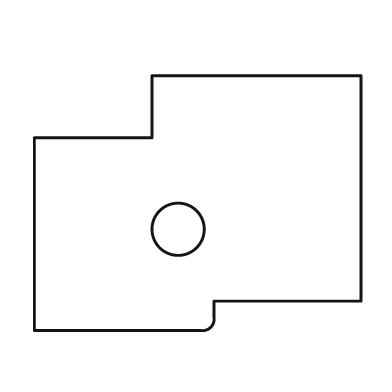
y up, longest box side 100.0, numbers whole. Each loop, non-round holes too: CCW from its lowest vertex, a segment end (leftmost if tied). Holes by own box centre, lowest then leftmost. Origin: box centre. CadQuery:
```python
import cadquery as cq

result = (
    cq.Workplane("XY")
    .moveTo(-50.0, -39.0)
    .lineTo(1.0, -39.0)
    .threePointArc((4.0, -38.0), (5.0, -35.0))
    .lineTo(5.0, -30.0)
    .lineTo(50.0, -30.0)
    .lineTo(50.0, 39.0)
    .lineTo(-14.0, 39.0)
    .lineTo(-14.0, 20.0)
    .lineTo(-50.0, 20.0)
    .close()
    .moveTo(-6.0, -8.0)
    .circle(8.0)
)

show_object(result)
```